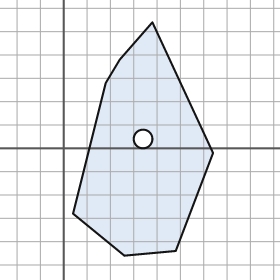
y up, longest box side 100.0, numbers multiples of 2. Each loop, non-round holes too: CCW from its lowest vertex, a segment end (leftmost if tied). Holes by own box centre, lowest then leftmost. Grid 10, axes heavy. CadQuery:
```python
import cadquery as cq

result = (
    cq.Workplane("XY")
    .moveTo(26.0, -46.0)
    .lineTo(48.0, -44.0)
    .lineTo(64.0, -2.0)
    .lineTo(38.0, 54.0)
    .lineTo(24.0, 38.0)
    .lineTo(18.0, 28.0)
    .lineTo(4.0, -28.0)
    .close()
    .moveTo(34.0, 4.0)
    .circle(4.0)
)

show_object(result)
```